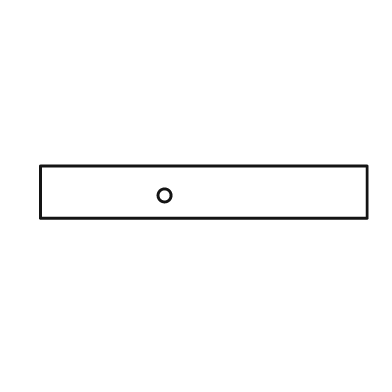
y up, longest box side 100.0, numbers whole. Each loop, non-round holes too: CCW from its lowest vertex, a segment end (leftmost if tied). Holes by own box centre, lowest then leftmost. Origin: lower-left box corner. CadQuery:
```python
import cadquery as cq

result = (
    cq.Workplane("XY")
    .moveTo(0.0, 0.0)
    .lineTo(100.0, 0.0)
    .lineTo(100.0, 16.0)
    .lineTo(0.0, 16.0)
    .close()
    .moveTo(38.0, 7.0)
    .circle(2.0)
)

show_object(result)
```